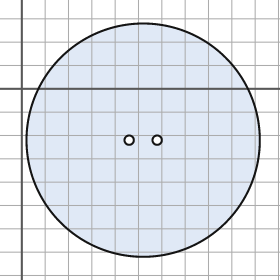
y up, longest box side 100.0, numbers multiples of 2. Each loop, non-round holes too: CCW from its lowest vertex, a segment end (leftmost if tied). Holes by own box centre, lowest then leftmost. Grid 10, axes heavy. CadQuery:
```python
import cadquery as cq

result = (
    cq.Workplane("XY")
    .moveTo(52.0, -22.0)
    .circle(50.0)
    .moveTo(46.0, -22.0)
    .circle(2.0)
    .moveTo(58.0, -22.0)
    .circle(2.0)
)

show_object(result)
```